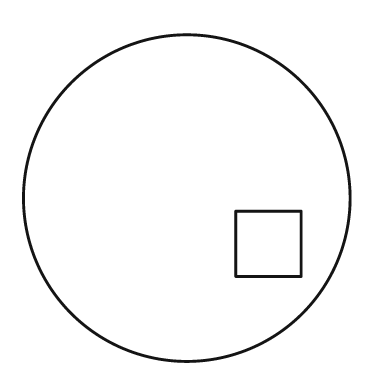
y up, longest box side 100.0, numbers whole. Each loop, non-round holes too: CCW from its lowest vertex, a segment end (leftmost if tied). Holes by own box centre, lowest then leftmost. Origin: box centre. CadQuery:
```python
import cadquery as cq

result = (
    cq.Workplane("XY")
    .moveTo(0.0, 0.0)
    .circle(50.0)
    .moveTo(15.0, -24.0)
    .lineTo(35.0, -24.0)
    .lineTo(35.0, -4.0)
    .lineTo(15.0, -4.0)
    .close()
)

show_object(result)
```